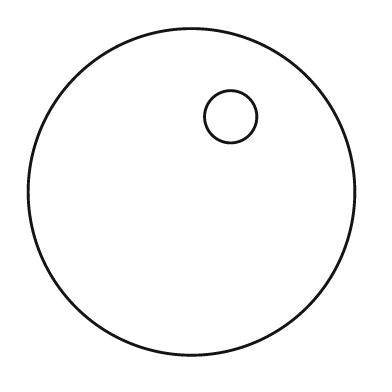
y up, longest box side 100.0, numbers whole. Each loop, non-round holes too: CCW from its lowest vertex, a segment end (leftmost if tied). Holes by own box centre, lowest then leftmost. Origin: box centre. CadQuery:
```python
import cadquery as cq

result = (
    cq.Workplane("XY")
    .moveTo(0.0, 0.0)
    .circle(50.0)
    .moveTo(12.0, 23.0)
    .circle(8.0)
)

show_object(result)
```